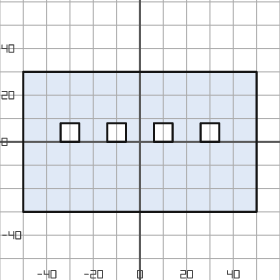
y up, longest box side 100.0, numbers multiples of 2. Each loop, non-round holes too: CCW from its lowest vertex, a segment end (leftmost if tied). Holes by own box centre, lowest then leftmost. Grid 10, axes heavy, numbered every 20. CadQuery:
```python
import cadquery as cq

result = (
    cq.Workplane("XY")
    .moveTo(-50.0, -30.0)
    .lineTo(50.0, -30.0)
    .lineTo(50.0, 30.0)
    .lineTo(-50.0, 30.0)
    .close()
    .moveTo(-34.0, 0.0)
    .lineTo(-26.0, 0.0)
    .lineTo(-26.0, 8.0)
    .lineTo(-34.0, 8.0)
    .close()
    .moveTo(-14.0, 0.0)
    .lineTo(-6.0, 0.0)
    .lineTo(-6.0, 8.0)
    .lineTo(-14.0, 8.0)
    .close()
    .moveTo(6.0, 0.0)
    .lineTo(14.0, 0.0)
    .lineTo(14.0, 8.0)
    .lineTo(6.0, 8.0)
    .close()
    .moveTo(26.0, 0.0)
    .lineTo(34.0, 0.0)
    .lineTo(34.0, 8.0)
    .lineTo(26.0, 8.0)
    .close()
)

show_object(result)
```